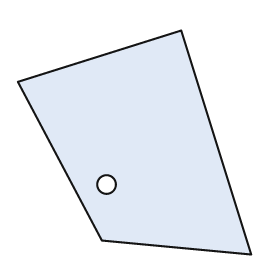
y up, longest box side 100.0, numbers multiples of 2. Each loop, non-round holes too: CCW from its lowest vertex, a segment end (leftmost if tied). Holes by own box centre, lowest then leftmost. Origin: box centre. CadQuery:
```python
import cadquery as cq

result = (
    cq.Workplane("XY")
    .moveTo(50.0, -48.0)
    .lineTo(20.0, 48.0)
    .lineTo(-50.0, 26.0)
    .lineTo(-14.0, -42.0)
    .close()
    .moveTo(-12.0, -18.0)
    .circle(4.0)
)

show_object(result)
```